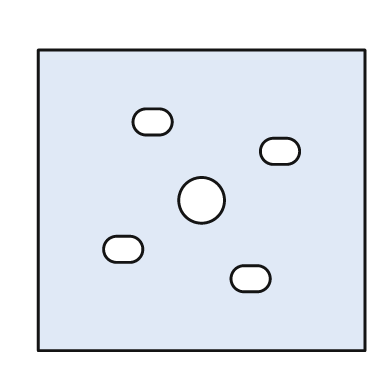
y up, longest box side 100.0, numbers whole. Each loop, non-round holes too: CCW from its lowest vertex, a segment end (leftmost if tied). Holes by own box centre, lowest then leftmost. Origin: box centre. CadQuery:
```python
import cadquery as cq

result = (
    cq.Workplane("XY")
    .moveTo(-50.0, -46.0)
    .lineTo(50.0, -46.0)
    .lineTo(50.0, 46.0)
    .lineTo(-50.0, 46.0)
    .close()
    .moveTo(13.0, -28.0)
    .lineTo(17.0, -28.0)
    .threePointArc((21.0, -24.0), (17.0, -20.0))
    .lineTo(13.0, -20.0)
    .threePointArc((9.0, -24.0), (13.0, -28.0))
    .close()
    .moveTo(-26.0, -19.0)
    .lineTo(-22.0, -19.0)
    .threePointArc((-18.0, -15.0), (-22.0, -11.0))
    .lineTo(-26.0, -11.0)
    .threePointArc((-30.0, -15.0), (-26.0, -19.0))
    .close()
    .moveTo(0.0, 0.0)
    .circle(7.0)
    .moveTo(22.0, 11.0)
    .lineTo(26.0, 11.0)
    .threePointArc((30.0, 15.0), (26.0, 19.0))
    .lineTo(22.0, 19.0)
    .threePointArc((18.0, 15.0), (22.0, 11.0))
    .close()
    .moveTo(-17.0, 20.0)
    .lineTo(-13.0, 20.0)
    .threePointArc((-9.0, 24.0), (-13.0, 28.0))
    .lineTo(-17.0, 28.0)
    .threePointArc((-21.0, 24.0), (-17.0, 20.0))
    .close()
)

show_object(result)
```